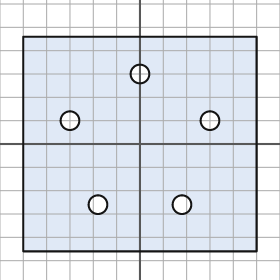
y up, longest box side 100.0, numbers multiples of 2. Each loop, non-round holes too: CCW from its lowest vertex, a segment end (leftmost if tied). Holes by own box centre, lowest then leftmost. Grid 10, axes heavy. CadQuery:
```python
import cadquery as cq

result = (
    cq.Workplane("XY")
    .moveTo(-50.0, -46.0)
    .lineTo(50.0, -46.0)
    .lineTo(50.0, 46.0)
    .lineTo(-50.0, 46.0)
    .close()
    .moveTo(-18.0, -26.0)
    .circle(4.0)
    .moveTo(18.0, -26.0)
    .circle(4.0)
    .moveTo(-30.0, 10.0)
    .circle(4.0)
    .moveTo(30.0, 10.0)
    .circle(4.0)
    .moveTo(0.0, 30.0)
    .circle(4.0)
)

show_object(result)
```